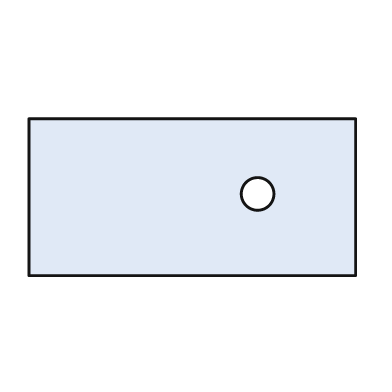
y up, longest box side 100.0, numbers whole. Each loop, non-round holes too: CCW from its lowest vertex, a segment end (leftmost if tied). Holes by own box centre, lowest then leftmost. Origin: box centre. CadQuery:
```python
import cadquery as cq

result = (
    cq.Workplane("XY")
    .moveTo(-50.0, -24.0)
    .lineTo(50.0, -24.0)
    .lineTo(50.0, 24.0)
    .lineTo(-50.0, 24.0)
    .close()
    .moveTo(20.0, 1.0)
    .circle(5.0)
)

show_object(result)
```